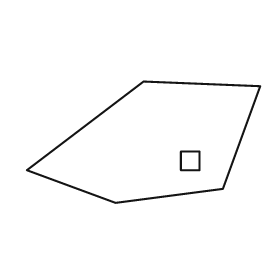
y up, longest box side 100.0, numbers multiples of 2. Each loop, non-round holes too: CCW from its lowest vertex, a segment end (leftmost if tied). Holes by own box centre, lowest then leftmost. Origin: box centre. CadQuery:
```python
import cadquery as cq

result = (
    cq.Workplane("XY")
    .moveTo(-12.0, -26.0)
    .lineTo(34.0, -20.0)
    .lineTo(50.0, 24.0)
    .lineTo(0.0, 26.0)
    .lineTo(-50.0, -12.0)
    .close()
    .moveTo(16.0, -12.0)
    .lineTo(24.0, -12.0)
    .lineTo(24.0, -4.0)
    .lineTo(16.0, -4.0)
    .close()
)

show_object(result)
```